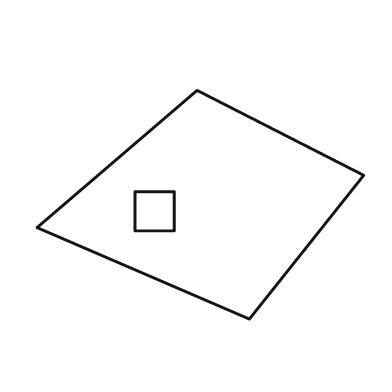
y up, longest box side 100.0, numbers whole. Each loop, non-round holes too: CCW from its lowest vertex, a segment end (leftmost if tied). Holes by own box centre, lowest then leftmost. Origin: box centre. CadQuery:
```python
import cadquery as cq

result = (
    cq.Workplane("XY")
    .moveTo(15.0, -35.0)
    .lineTo(50.0, 9.0)
    .lineTo(-1.0, 35.0)
    .lineTo(-50.0, -7.0)
    .close()
    .moveTo(-20.0, -8.0)
    .lineTo(-8.0, -8.0)
    .lineTo(-8.0, 4.0)
    .lineTo(-20.0, 4.0)
    .close()
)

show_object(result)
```